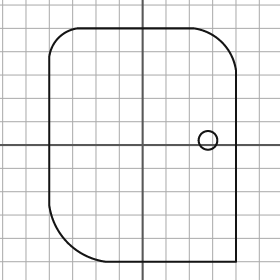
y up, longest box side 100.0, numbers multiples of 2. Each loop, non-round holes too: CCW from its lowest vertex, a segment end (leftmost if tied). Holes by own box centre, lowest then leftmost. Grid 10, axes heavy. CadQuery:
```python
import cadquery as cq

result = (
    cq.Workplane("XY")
    .moveTo(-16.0, -50.0)
    .lineTo(40.0, -50.0)
    .lineTo(40.0, 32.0)
    .threePointArc((34.0, 44.0), (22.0, 50.0))
    .lineTo(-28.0, 50.0)
    .threePointArc((-36.0, 46.0), (-40.0, 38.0))
    .lineTo(-40.0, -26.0)
    .threePointArc((-32.0, -42.0), (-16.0, -50.0))
    .close()
    .moveTo(28.0, 2.0)
    .circle(4.0)
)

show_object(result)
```